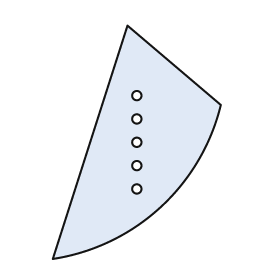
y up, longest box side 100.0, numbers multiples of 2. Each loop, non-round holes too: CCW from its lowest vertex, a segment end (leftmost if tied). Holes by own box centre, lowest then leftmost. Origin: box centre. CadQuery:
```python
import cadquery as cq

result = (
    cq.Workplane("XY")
    .moveTo(-36.0, -50.0)
    .threePointArc((10.0, -28.0), (36.0, 16.0))
    .lineTo(-4.0, 50.0)
    .close()
    .moveTo(0.0, -20.0)
    .circle(2.0)
    .moveTo(0.0, -10.0)
    .circle(2.0)
    .moveTo(0.0, 0.0)
    .circle(2.0)
    .moveTo(0.0, 10.0)
    .circle(2.0)
    .moveTo(0.0, 20.0)
    .circle(2.0)
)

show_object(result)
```